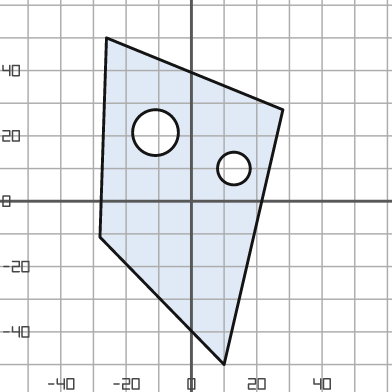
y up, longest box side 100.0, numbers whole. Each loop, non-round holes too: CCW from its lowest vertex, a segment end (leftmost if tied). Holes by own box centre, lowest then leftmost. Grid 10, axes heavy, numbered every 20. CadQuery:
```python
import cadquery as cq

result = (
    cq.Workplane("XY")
    .moveTo(10.0, -50.0)
    .lineTo(28.0, 28.0)
    .lineTo(-26.0, 50.0)
    .lineTo(-28.0, -11.0)
    .close()
    .moveTo(13.0, 10.0)
    .circle(5.0)
    .moveTo(-11.0, 21.0)
    .circle(7.0)
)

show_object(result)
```